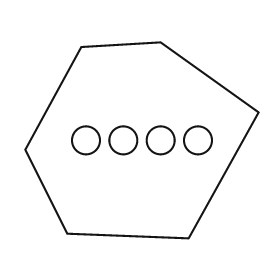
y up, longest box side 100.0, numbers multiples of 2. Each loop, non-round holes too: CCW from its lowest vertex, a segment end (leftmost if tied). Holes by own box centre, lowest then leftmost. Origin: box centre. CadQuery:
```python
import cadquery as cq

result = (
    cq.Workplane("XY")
    .moveTo(20.0, -42.0)
    .lineTo(50.0, 12.0)
    .lineTo(8.0, 42.0)
    .lineTo(-26.0, 40.0)
    .lineTo(-50.0, -4.0)
    .lineTo(-32.0, -40.0)
    .close()
    .moveTo(-24.0, 0.0)
    .circle(6.0)
    .moveTo(-8.0, 0.0)
    .circle(6.0)
    .moveTo(8.0, 0.0)
    .circle(6.0)
    .moveTo(24.0, 0.0)
    .circle(6.0)
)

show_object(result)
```